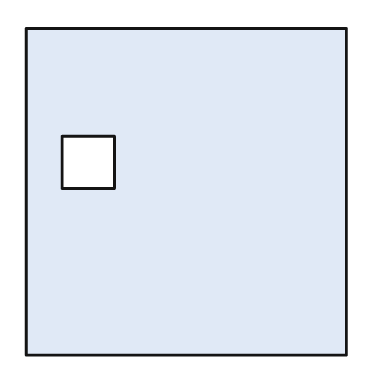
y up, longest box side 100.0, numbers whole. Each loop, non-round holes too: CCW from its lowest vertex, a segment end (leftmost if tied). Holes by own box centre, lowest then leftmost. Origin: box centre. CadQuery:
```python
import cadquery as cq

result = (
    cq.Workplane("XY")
    .moveTo(-49.0, -50.0)
    .lineTo(49.0, -50.0)
    .lineTo(49.0, 50.0)
    .lineTo(-49.0, 50.0)
    .close()
    .moveTo(-38.0, 1.0)
    .lineTo(-22.0, 1.0)
    .lineTo(-22.0, 17.0)
    .lineTo(-38.0, 17.0)
    .close()
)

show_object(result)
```